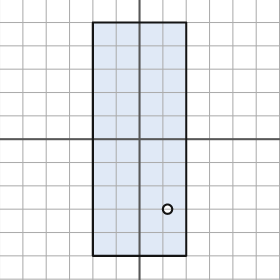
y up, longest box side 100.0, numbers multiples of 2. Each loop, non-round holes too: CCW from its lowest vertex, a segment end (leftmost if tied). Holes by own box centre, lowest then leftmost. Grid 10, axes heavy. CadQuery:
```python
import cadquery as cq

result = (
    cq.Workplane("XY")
    .moveTo(-20.0, -50.0)
    .lineTo(20.0, -50.0)
    .lineTo(20.0, 50.0)
    .lineTo(-20.0, 50.0)
    .close()
    .moveTo(12.0, -30.0)
    .circle(2.0)
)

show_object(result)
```